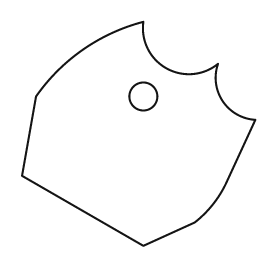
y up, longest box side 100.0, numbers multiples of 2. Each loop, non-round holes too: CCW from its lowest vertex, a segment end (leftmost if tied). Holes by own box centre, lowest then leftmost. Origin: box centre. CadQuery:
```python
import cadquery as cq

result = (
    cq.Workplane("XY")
    .moveTo(2.0, -48.0)
    .lineTo(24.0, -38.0)
    .threePointArc((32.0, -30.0), (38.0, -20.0))
    .lineTo(50.0, 6.0)
    .threePointArc((36.0, 14.0), (34.0, 30.0))
    .threePointArc((12.0, 28.0), (2.0, 48.0))
    .threePointArc((-24.0, 36.0), (-44.0, 16.0))
    .lineTo(-50.0, -18.0)
    .close()
    .moveTo(2.0, 16.0)
    .circle(6.0)
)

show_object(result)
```